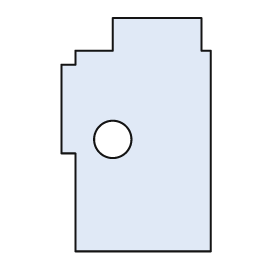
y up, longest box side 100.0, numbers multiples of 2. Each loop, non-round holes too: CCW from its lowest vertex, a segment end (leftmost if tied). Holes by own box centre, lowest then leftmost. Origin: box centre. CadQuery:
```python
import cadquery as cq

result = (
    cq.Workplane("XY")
    .moveTo(-26.0, -50.0)
    .lineTo(32.0, -50.0)
    .lineTo(32.0, 36.0)
    .lineTo(28.0, 36.0)
    .lineTo(28.0, 50.0)
    .lineTo(-10.0, 50.0)
    .lineTo(-10.0, 36.0)
    .lineTo(-26.0, 36.0)
    .lineTo(-26.0, 30.0)
    .lineTo(-32.0, 30.0)
    .lineTo(-32.0, -8.0)
    .lineTo(-26.0, -8.0)
    .close()
    .moveTo(-10.0, -2.0)
    .circle(8.0)
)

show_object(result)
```